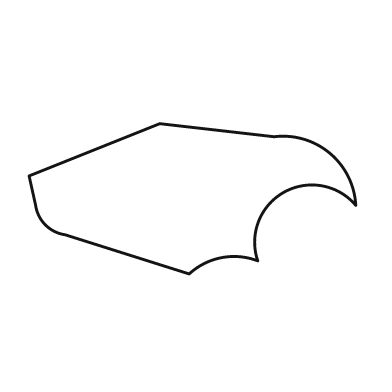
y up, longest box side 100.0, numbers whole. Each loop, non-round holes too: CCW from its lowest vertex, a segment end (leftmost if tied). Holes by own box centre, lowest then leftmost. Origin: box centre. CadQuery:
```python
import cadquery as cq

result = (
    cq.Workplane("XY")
    .moveTo(-1.0, -23.0)
    .threePointArc((9.0, -18.0), (20.0, -19.0))
    .threePointArc((28.0, 2.0), (50.0, -2.0))
    .threePointArc((42.0, 14.0), (25.0, 19.0))
    .lineTo(-10.0, 23.0)
    .lineTo(-50.0, 7.0)
    .lineTo(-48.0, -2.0)
    .threePointArc((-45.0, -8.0), (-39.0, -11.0))
    .close()
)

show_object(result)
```